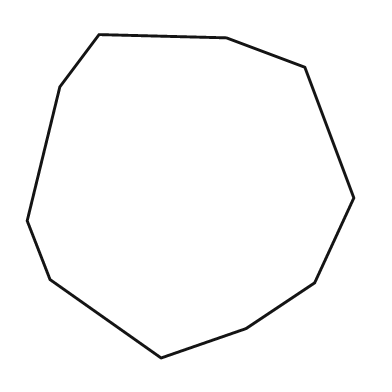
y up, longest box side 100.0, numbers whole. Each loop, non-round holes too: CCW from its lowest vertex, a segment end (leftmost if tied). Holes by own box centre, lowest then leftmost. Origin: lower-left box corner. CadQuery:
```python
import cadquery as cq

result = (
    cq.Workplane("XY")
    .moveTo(41.0, 0.0)
    .lineTo(67.0, 9.0)
    .lineTo(88.0, 23.0)
    .lineTo(100.0, 49.0)
    .lineTo(85.0, 89.0)
    .lineTo(61.0, 98.0)
    .lineTo(22.0, 99.0)
    .lineTo(10.0, 83.0)
    .lineTo(0.0, 42.0)
    .lineTo(7.0, 24.0)
    .close()
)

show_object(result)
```